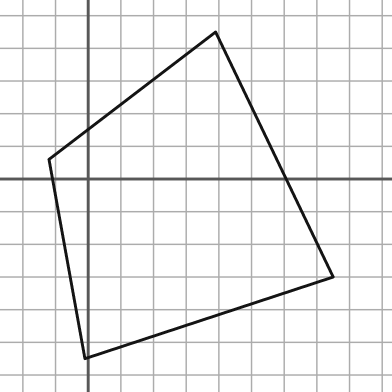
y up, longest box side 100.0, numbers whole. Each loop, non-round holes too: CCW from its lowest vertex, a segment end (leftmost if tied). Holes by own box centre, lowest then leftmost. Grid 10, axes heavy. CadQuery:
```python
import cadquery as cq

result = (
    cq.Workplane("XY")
    .moveTo(-1.0, -55.0)
    .lineTo(75.0, -30.0)
    .lineTo(39.0, 45.0)
    .lineTo(-12.0, 6.0)
    .close()
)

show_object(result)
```